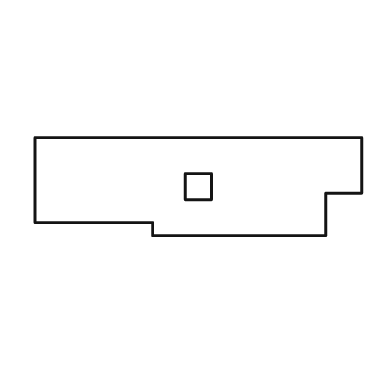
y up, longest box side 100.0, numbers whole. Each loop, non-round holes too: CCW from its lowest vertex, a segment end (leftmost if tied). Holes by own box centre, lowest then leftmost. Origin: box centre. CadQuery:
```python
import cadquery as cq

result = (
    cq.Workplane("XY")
    .moveTo(-14.0, -15.0)
    .lineTo(39.0, -15.0)
    .lineTo(39.0, -2.0)
    .lineTo(50.0, -2.0)
    .lineTo(50.0, 15.0)
    .lineTo(-50.0, 15.0)
    .lineTo(-50.0, -11.0)
    .lineTo(-14.0, -11.0)
    .close()
    .moveTo(-4.0, -4.0)
    .lineTo(4.0, -4.0)
    .lineTo(4.0, 4.0)
    .lineTo(-4.0, 4.0)
    .close()
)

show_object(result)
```